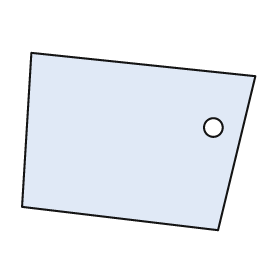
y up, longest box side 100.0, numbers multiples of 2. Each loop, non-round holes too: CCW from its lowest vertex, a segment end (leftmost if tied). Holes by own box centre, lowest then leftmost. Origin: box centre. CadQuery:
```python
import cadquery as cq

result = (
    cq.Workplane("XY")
    .moveTo(34.0, -38.0)
    .lineTo(50.0, 28.0)
    .lineTo(-46.0, 38.0)
    .lineTo(-50.0, -28.0)
    .close()
    .moveTo(32.0, 6.0)
    .circle(4.0)
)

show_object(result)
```